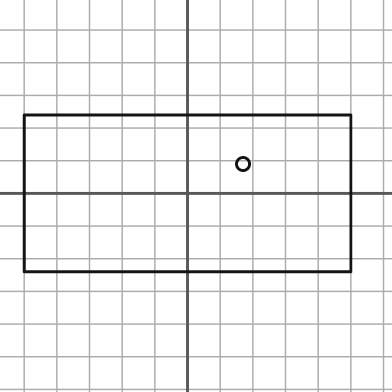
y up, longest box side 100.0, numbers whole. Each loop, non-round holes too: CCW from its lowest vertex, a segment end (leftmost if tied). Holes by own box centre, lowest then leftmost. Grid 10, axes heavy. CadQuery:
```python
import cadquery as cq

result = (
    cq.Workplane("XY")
    .moveTo(-50.0, -24.0)
    .lineTo(50.0, -24.0)
    .lineTo(50.0, 24.0)
    .lineTo(-50.0, 24.0)
    .close()
    .moveTo(17.0, 9.0)
    .circle(2.0)
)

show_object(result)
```